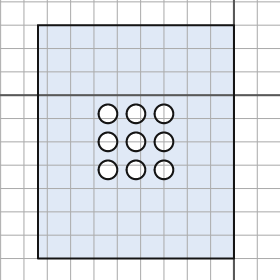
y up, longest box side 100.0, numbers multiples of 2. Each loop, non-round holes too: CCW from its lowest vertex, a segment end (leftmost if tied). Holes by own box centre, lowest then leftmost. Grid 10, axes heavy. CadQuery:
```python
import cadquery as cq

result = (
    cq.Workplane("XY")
    .moveTo(-84.0, -70.0)
    .lineTo(0.0, -70.0)
    .lineTo(0.0, 30.0)
    .lineTo(-84.0, 30.0)
    .close()
    .moveTo(-54.0, -32.0)
    .circle(4.0)
    .moveTo(-42.0, -32.0)
    .circle(4.0)
    .moveTo(-30.0, -32.0)
    .circle(4.0)
    .moveTo(-54.0, -20.0)
    .circle(4.0)
    .moveTo(-42.0, -20.0)
    .circle(4.0)
    .moveTo(-30.0, -20.0)
    .circle(4.0)
    .moveTo(-54.0, -8.0)
    .circle(4.0)
    .moveTo(-42.0, -8.0)
    .circle(4.0)
    .moveTo(-30.0, -8.0)
    .circle(4.0)
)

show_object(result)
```